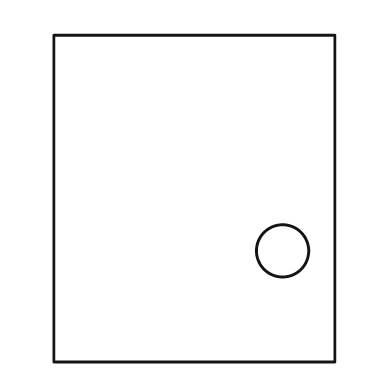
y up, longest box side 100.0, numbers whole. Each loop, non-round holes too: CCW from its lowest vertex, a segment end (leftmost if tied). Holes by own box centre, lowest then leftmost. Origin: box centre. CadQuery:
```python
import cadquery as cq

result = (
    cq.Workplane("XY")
    .moveTo(-43.0, -50.0)
    .lineTo(43.0, -50.0)
    .lineTo(43.0, 50.0)
    .lineTo(-43.0, 50.0)
    .close()
    .moveTo(27.0, -16.0)
    .circle(8.0)
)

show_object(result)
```